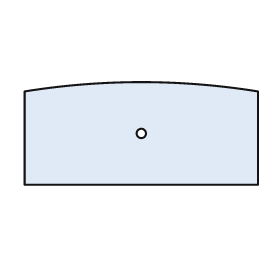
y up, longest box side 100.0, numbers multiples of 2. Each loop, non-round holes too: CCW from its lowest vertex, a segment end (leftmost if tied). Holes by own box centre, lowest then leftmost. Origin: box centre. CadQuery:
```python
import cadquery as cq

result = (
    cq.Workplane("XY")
    .moveTo(-50.0, -22.0)
    .lineTo(50.0, -22.0)
    .lineTo(50.0, 18.0)
    .threePointArc((0.0, 22.0), (-50.0, 18.0))
    .close()
    .moveTo(0.0, 0.0)
    .circle(2.0)
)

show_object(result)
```